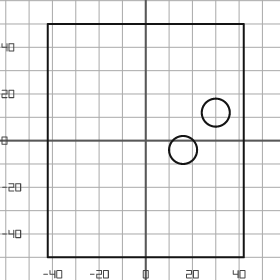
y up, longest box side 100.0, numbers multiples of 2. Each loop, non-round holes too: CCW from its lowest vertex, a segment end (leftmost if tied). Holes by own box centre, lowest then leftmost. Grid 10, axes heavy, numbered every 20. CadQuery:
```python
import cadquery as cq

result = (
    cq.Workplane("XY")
    .moveTo(-42.0, -50.0)
    .lineTo(42.0, -50.0)
    .lineTo(42.0, 50.0)
    .lineTo(-42.0, 50.0)
    .close()
    .moveTo(16.0, -4.0)
    .circle(6.0)
    .moveTo(30.0, 12.0)
    .circle(6.0)
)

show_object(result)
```